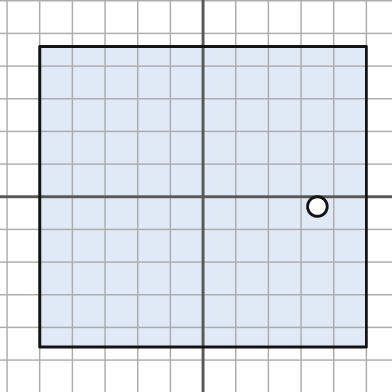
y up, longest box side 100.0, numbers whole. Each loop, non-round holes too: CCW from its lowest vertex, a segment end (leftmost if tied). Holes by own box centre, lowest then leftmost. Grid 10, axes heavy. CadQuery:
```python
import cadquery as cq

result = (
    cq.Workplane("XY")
    .moveTo(-50.0, -46.0)
    .lineTo(50.0, -46.0)
    .lineTo(50.0, 46.0)
    .lineTo(-50.0, 46.0)
    .close()
    .moveTo(35.0, -3.0)
    .circle(3.0)
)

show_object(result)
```